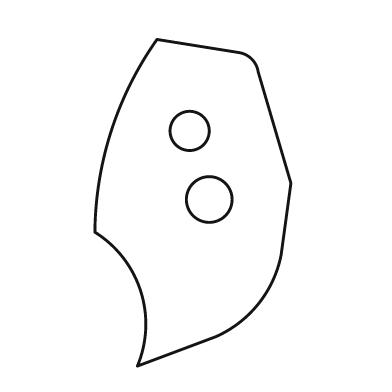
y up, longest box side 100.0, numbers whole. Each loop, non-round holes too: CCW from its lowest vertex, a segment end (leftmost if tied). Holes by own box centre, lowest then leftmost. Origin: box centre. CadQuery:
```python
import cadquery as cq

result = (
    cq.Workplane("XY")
    .moveTo(-17.0, -50.0)
    .lineTo(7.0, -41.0)
    .threePointArc((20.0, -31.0), (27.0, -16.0))
    .lineTo(30.0, 6.0)
    .lineTo(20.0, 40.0)
    .threePointArc((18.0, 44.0), (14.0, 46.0))
    .lineTo(-11.0, 50.0)
    .threePointArc((-25.0, 22.0), (-30.0, -9.0))
    .threePointArc((-16.0, -27.0), (-17.0, -50.0))
    .close()
    .moveTo(5.0, 1.0)
    .circle(7.0)
    .moveTo(-1.0, 22.0)
    .circle(6.0)
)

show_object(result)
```